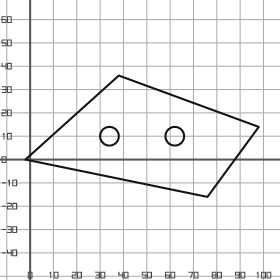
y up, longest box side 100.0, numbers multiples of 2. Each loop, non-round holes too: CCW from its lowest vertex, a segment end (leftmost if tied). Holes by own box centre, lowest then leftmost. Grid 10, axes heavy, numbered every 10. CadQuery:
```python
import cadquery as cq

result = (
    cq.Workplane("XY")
    .moveTo(76.0, -16.0)
    .lineTo(98.0, 14.0)
    .lineTo(38.0, 36.0)
    .lineTo(-2.0, 0.0)
    .close()
    .moveTo(34.0, 10.0)
    .circle(4.0)
    .moveTo(62.0, 10.0)
    .circle(4.0)
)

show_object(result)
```